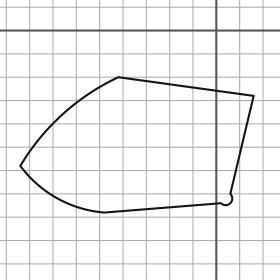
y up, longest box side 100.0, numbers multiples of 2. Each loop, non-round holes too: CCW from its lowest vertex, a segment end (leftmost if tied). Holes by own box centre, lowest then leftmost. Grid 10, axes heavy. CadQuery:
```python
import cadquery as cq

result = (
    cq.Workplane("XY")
    .moveTo(-48.0, -78.0)
    .lineTo(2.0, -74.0)
    .threePointArc((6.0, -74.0), (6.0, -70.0))
    .lineTo(16.0, -28.0)
    .lineTo(-42.0, -20.0)
    .threePointArc((-66.0, -36.0), (-84.0, -58.0))
    .threePointArc((-68.0, -72.0), (-48.0, -78.0))
    .close()
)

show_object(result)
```